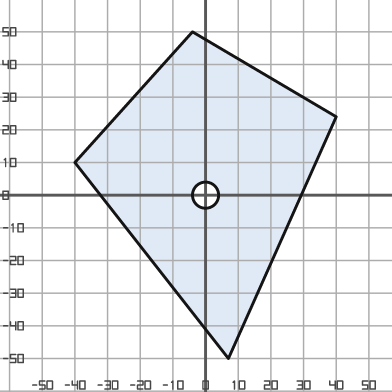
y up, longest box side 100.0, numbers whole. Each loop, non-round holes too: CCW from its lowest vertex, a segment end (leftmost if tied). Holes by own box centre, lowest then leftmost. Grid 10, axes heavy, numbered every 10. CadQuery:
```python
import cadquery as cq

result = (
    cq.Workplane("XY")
    .moveTo(7.0, -50.0)
    .lineTo(40.0, 24.0)
    .lineTo(-4.0, 50.0)
    .lineTo(-40.0, 10.0)
    .close()
    .moveTo(0.0, 0.0)
    .circle(4.0)
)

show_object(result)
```